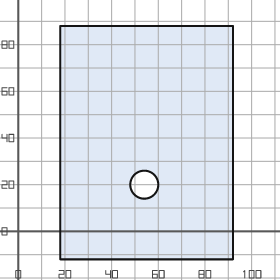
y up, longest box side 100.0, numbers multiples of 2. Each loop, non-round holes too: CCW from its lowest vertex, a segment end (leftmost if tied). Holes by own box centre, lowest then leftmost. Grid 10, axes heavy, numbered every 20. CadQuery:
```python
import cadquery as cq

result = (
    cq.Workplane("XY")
    .moveTo(18.0, -12.0)
    .lineTo(92.0, -12.0)
    .lineTo(92.0, 88.0)
    .lineTo(18.0, 88.0)
    .close()
    .moveTo(54.0, 20.0)
    .circle(6.0)
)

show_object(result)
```